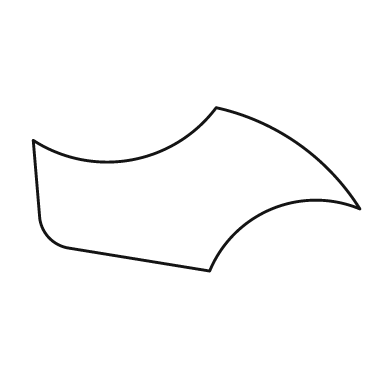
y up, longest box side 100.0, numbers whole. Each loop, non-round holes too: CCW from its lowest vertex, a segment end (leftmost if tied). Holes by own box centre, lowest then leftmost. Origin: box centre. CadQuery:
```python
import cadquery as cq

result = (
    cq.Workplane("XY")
    .moveTo(4.0, -25.0)
    .threePointArc((23.0, -6.0), (50.0, -6.0))
    .threePointArc((31.0, 14.0), (6.0, 25.0))
    .threePointArc((-20.0, 9.0), (-50.0, 15.0))
    .lineTo(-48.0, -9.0)
    .threePointArc((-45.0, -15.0), (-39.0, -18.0))
    .close()
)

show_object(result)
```